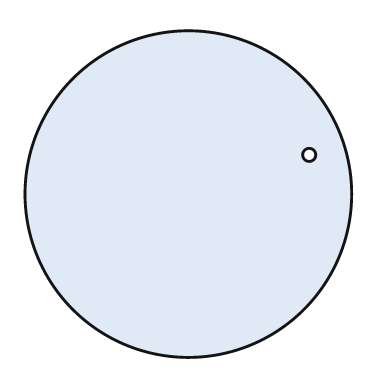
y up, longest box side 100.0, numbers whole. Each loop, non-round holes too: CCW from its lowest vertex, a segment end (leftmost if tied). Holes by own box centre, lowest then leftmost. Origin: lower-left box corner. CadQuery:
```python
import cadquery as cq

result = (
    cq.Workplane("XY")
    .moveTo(50.0, 50.0)
    .circle(50.0)
    .moveTo(87.0, 62.0)
    .circle(2.0)
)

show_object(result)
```